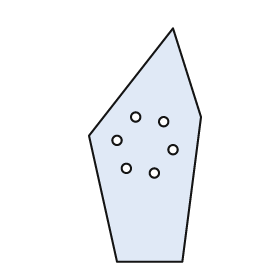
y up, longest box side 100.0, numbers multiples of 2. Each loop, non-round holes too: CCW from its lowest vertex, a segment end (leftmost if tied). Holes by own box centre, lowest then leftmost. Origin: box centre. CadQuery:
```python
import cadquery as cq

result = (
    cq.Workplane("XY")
    .moveTo(-12.0, -50.0)
    .lineTo(16.0, -50.0)
    .lineTo(24.0, 12.0)
    .lineTo(12.0, 50.0)
    .lineTo(-24.0, 4.0)
    .close()
    .moveTo(4.0, -12.0)
    .circle(2.0)
    .moveTo(-8.0, -10.0)
    .circle(2.0)
    .moveTo(12.0, -2.0)
    .circle(2.0)
    .moveTo(-12.0, 2.0)
    .circle(2.0)
    .moveTo(8.0, 10.0)
    .circle(2.0)
    .moveTo(-4.0, 12.0)
    .circle(2.0)
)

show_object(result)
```